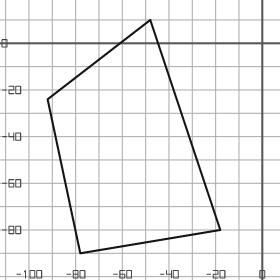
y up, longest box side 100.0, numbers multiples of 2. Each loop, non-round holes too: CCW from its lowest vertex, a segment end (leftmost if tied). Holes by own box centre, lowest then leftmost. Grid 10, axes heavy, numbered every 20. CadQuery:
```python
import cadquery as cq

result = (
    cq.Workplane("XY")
    .moveTo(-78.0, -90.0)
    .lineTo(-18.0, -80.0)
    .lineTo(-48.0, 10.0)
    .lineTo(-92.0, -24.0)
    .close()
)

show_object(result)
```